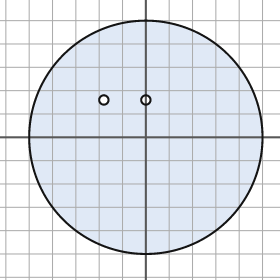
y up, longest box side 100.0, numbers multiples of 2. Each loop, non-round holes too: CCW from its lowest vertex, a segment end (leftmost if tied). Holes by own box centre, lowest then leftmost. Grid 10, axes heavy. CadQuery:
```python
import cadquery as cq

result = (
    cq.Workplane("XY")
    .moveTo(0.0, 0.0)
    .circle(50.0)
    .moveTo(-18.0, 16.0)
    .circle(2.0)
    .moveTo(0.0, 16.0)
    .circle(2.0)
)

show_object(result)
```